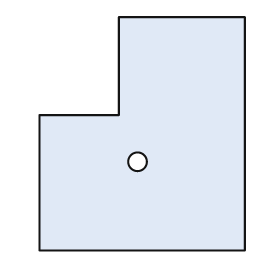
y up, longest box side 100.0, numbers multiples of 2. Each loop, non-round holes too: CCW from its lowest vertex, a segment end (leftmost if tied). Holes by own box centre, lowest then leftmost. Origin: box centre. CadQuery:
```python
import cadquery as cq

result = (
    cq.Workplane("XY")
    .moveTo(-44.0, -50.0)
    .lineTo(44.0, -50.0)
    .lineTo(44.0, 50.0)
    .lineTo(-10.0, 50.0)
    .lineTo(-10.0, 8.0)
    .lineTo(-44.0, 8.0)
    .close()
    .moveTo(-2.0, -12.0)
    .circle(4.0)
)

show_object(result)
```